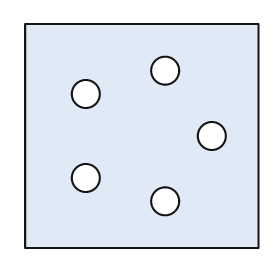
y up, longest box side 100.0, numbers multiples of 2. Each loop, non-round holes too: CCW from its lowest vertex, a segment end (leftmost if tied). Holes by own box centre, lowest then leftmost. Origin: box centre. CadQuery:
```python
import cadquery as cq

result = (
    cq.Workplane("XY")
    .moveTo(-50.0, -48.0)
    .lineTo(50.0, -48.0)
    .lineTo(50.0, 48.0)
    .lineTo(-50.0, 48.0)
    .close()
    .moveTo(10.0, -28.0)
    .circle(6.0)
    .moveTo(-24.0, -18.0)
    .circle(6.0)
    .moveTo(30.0, 0.0)
    .circle(6.0)
    .moveTo(-24.0, 18.0)
    .circle(6.0)
    .moveTo(10.0, 28.0)
    .circle(6.0)
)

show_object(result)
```